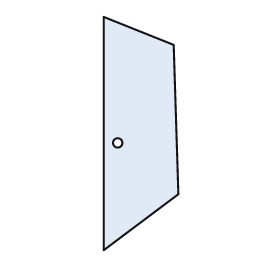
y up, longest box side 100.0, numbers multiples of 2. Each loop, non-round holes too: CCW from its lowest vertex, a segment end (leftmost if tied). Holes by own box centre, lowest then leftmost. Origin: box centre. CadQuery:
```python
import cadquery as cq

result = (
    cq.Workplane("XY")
    .moveTo(-16.0, -50.0)
    .lineTo(16.0, -26.0)
    .lineTo(14.0, 38.0)
    .lineTo(-16.0, 50.0)
    .close()
    .moveTo(-10.0, -4.0)
    .circle(2.0)
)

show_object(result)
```